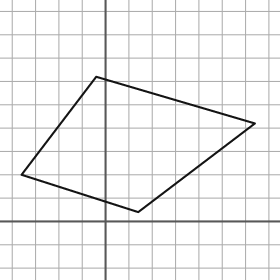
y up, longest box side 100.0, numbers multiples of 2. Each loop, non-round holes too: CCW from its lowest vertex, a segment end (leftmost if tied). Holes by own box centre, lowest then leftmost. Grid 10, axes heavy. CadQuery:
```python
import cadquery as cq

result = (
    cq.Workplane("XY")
    .moveTo(14.0, 4.0)
    .lineTo(64.0, 42.0)
    .lineTo(-4.0, 62.0)
    .lineTo(-36.0, 20.0)
    .close()
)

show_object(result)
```